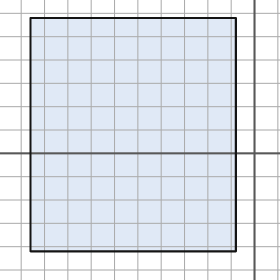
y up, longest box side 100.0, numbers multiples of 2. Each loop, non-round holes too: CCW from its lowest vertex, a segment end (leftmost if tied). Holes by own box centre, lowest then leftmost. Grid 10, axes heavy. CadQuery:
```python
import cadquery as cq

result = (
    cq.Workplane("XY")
    .moveTo(-96.0, -42.0)
    .lineTo(-8.0, -42.0)
    .lineTo(-8.0, 58.0)
    .lineTo(-96.0, 58.0)
    .close()
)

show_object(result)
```